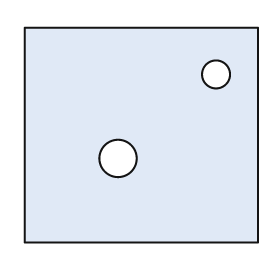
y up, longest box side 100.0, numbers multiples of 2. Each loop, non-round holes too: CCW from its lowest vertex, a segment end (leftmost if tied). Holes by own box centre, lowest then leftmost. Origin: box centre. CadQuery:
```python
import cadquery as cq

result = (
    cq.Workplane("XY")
    .moveTo(-50.0, -46.0)
    .lineTo(50.0, -46.0)
    .lineTo(50.0, 46.0)
    .lineTo(-50.0, 46.0)
    .close()
    .moveTo(-10.0, -10.0)
    .circle(8.0)
    .moveTo(32.0, 26.0)
    .circle(6.0)
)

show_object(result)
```